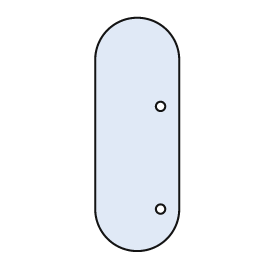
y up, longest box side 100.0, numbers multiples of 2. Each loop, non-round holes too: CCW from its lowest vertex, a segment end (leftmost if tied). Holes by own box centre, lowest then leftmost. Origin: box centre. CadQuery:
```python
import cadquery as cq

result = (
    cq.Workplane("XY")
    .moveTo(-18.0, -32.0)
    .threePointArc((0.0, -50.0), (18.0, -32.0))
    .lineTo(18.0, 32.0)
    .threePointArc((0.0, 50.0), (-18.0, 32.0))
    .close()
    .moveTo(10.0, -32.0)
    .circle(2.0)
    .moveTo(10.0, 12.0)
    .circle(2.0)
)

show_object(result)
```